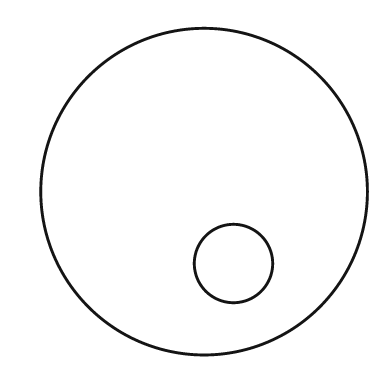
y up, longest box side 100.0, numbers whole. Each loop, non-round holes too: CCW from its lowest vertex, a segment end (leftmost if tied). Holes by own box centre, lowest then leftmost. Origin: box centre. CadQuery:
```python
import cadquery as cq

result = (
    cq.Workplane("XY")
    .moveTo(0.0, 0.0)
    .circle(50.0)
    .moveTo(9.0, -22.0)
    .circle(12.0)
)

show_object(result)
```